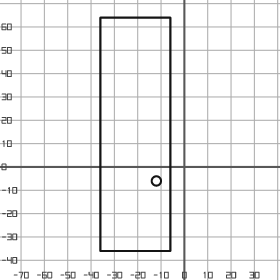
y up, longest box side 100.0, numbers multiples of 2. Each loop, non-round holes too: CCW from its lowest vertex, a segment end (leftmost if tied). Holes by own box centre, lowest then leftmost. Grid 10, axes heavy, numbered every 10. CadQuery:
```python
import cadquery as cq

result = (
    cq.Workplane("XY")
    .moveTo(-36.0, -36.0)
    .lineTo(-6.0, -36.0)
    .lineTo(-6.0, 64.0)
    .lineTo(-36.0, 64.0)
    .close()
    .moveTo(-12.0, -6.0)
    .circle(2.0)
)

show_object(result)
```